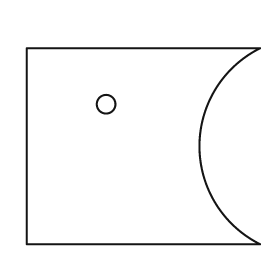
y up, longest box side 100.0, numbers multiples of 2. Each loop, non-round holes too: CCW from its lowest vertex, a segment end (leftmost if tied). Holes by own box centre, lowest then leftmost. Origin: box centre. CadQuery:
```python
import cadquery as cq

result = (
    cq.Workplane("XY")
    .moveTo(-50.0, -42.0)
    .lineTo(50.0, -42.0)
    .threePointArc((24.0, 0.0), (50.0, 42.0))
    .lineTo(-50.0, 42.0)
    .close()
    .moveTo(-16.0, 18.0)
    .circle(4.0)
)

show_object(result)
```